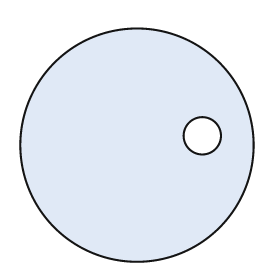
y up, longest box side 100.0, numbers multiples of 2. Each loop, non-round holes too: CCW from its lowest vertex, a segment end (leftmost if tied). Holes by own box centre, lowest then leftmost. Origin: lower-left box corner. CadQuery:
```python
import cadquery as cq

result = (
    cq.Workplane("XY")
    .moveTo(50.0, 50.0)
    .circle(50.0)
    .moveTo(78.0, 54.0)
    .circle(8.0)
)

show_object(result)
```